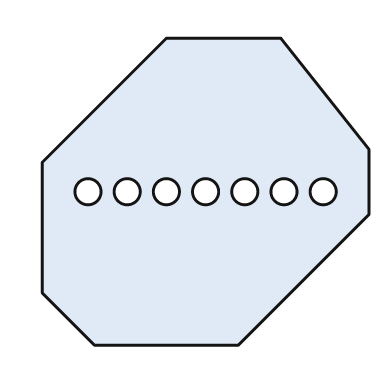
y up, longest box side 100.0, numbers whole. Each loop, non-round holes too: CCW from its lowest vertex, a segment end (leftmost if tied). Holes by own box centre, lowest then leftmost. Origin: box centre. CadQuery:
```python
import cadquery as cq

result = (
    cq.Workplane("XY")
    .moveTo(-34.0, -47.0)
    .lineTo(10.0, -47.0)
    .lineTo(50.0, -7.0)
    .lineTo(50.0, 13.0)
    .lineTo(23.0, 47.0)
    .lineTo(-12.0, 47.0)
    .lineTo(-50.0, 9.0)
    .lineTo(-50.0, -31.0)
    .close()
    .moveTo(-36.0, 0.0)
    .circle(4.0)
    .moveTo(-24.0, 0.0)
    .circle(4.0)
    .moveTo(-12.0, 0.0)
    .circle(4.0)
    .moveTo(0.0, 0.0)
    .circle(4.0)
    .moveTo(12.0, 0.0)
    .circle(4.0)
    .moveTo(24.0, 0.0)
    .circle(4.0)
    .moveTo(36.0, 0.0)
    .circle(4.0)
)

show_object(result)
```